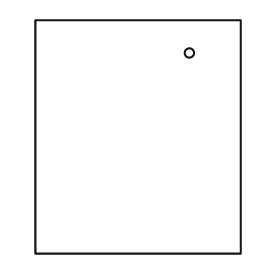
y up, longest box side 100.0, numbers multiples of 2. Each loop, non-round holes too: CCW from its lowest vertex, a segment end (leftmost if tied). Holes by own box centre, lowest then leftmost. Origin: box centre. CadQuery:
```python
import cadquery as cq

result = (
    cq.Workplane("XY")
    .moveTo(-44.0, -50.0)
    .lineTo(44.0, -50.0)
    .lineTo(44.0, 50.0)
    .lineTo(-44.0, 50.0)
    .close()
    .moveTo(22.0, 36.0)
    .circle(2.0)
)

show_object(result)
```